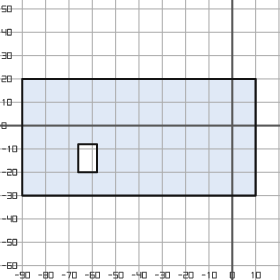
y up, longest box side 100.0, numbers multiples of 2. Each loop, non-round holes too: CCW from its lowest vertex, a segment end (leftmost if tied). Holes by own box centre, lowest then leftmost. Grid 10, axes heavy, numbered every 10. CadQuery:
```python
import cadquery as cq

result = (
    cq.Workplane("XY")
    .moveTo(-90.0, -30.0)
    .lineTo(10.0, -30.0)
    .lineTo(10.0, 20.0)
    .lineTo(-90.0, 20.0)
    .close()
    .moveTo(-66.0, -20.0)
    .lineTo(-58.0, -20.0)
    .lineTo(-58.0, -8.0)
    .lineTo(-66.0, -8.0)
    .close()
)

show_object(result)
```